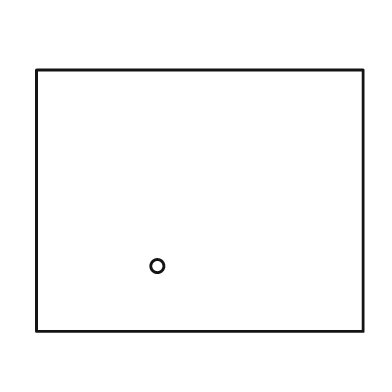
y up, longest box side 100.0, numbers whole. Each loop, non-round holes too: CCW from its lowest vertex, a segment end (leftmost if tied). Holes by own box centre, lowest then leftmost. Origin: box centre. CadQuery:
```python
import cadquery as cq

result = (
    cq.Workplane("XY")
    .moveTo(-50.0, -40.0)
    .lineTo(50.0, -40.0)
    .lineTo(50.0, 40.0)
    .lineTo(-50.0, 40.0)
    .close()
    .moveTo(-13.0, -20.0)
    .circle(2.0)
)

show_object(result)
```